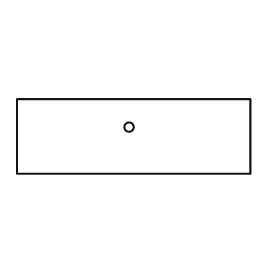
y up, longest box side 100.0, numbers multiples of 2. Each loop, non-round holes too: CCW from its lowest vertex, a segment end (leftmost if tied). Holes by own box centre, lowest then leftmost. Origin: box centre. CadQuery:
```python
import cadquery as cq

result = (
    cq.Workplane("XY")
    .moveTo(-50.0, -16.0)
    .lineTo(50.0, -16.0)
    .lineTo(50.0, 16.0)
    .lineTo(-50.0, 16.0)
    .close()
    .moveTo(-2.0, 4.0)
    .circle(2.0)
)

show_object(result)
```